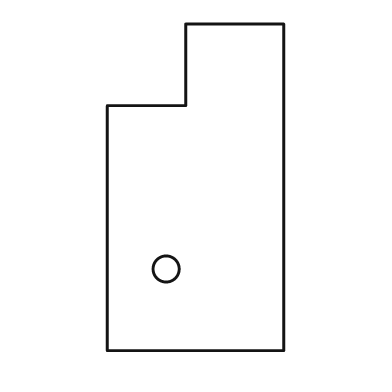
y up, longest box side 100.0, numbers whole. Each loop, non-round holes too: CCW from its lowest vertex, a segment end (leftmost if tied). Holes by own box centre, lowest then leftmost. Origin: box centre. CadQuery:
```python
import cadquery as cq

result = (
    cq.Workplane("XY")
    .moveTo(-27.0, -50.0)
    .lineTo(27.0, -50.0)
    .lineTo(27.0, 50.0)
    .lineTo(-3.0, 50.0)
    .lineTo(-3.0, 25.0)
    .lineTo(-27.0, 25.0)
    .close()
    .moveTo(-9.0, -25.0)
    .circle(4.0)
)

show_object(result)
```